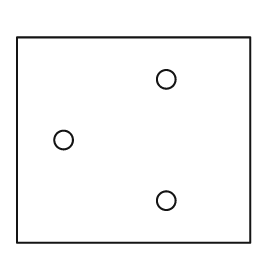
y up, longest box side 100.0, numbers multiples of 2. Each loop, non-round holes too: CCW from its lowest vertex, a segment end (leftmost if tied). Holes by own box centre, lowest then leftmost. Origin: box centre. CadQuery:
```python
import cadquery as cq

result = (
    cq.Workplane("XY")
    .moveTo(-50.0, -44.0)
    .lineTo(50.0, -44.0)
    .lineTo(50.0, 44.0)
    .lineTo(-50.0, 44.0)
    .close()
    .moveTo(14.0, -26.0)
    .circle(4.0)
    .moveTo(-30.0, 0.0)
    .circle(4.0)
    .moveTo(14.0, 26.0)
    .circle(4.0)
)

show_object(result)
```